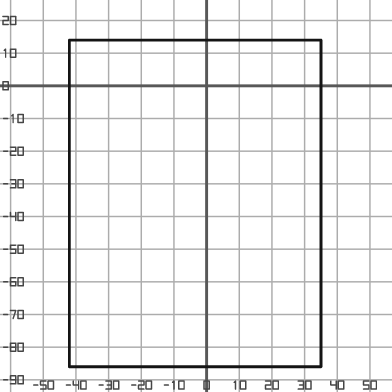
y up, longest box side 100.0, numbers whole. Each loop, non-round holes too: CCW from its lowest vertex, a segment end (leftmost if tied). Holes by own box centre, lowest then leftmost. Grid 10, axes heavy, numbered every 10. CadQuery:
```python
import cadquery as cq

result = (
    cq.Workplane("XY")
    .moveTo(-42.0, -86.0)
    .lineTo(35.0, -86.0)
    .lineTo(35.0, 14.0)
    .lineTo(-42.0, 14.0)
    .close()
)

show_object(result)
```